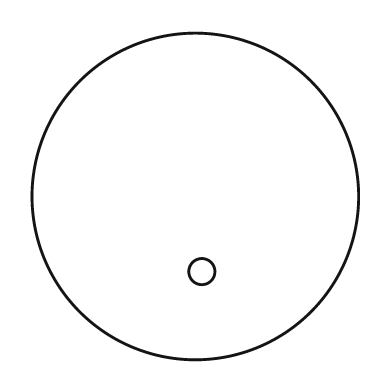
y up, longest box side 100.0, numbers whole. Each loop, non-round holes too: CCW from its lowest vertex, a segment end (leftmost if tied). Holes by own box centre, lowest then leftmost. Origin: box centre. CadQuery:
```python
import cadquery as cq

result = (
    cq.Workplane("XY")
    .moveTo(0.0, 0.0)
    .circle(50.0)
    .moveTo(2.0, -23.0)
    .circle(4.0)
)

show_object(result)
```